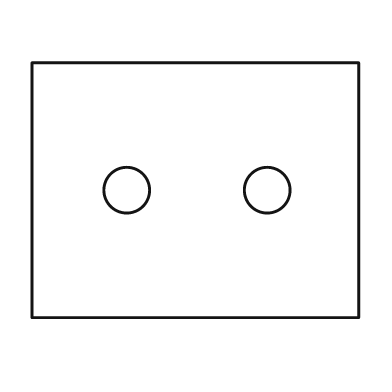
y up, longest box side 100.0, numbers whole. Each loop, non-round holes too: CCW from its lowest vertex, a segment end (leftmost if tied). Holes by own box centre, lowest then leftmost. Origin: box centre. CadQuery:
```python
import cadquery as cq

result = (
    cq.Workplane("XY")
    .moveTo(-50.0, -39.0)
    .lineTo(50.0, -39.0)
    .lineTo(50.0, 39.0)
    .lineTo(-50.0, 39.0)
    .close()
    .moveTo(-21.0, 0.0)
    .circle(7.0)
    .moveTo(22.0, 0.0)
    .circle(7.0)
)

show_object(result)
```